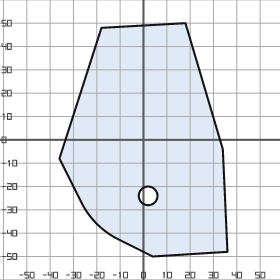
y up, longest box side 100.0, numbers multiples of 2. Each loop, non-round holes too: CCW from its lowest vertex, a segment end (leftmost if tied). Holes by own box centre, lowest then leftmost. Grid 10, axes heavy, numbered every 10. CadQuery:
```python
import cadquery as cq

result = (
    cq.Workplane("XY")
    .moveTo(4.0, -50.0)
    .lineTo(36.0, -48.0)
    .lineTo(34.0, -4.0)
    .lineTo(18.0, 50.0)
    .lineTo(-18.0, 48.0)
    .lineTo(-36.0, -8.0)
    .lineTo(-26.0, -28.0)
    .threePointArc((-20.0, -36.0), (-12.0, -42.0))
    .close()
    .moveTo(2.0, -24.0)
    .circle(4.0)
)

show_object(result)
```